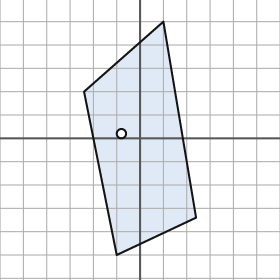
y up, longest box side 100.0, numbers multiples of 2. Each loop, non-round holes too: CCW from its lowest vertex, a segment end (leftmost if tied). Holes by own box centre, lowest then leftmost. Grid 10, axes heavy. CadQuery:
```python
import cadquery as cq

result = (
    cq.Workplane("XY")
    .moveTo(-10.0, -50.0)
    .lineTo(24.0, -34.0)
    .lineTo(10.0, 50.0)
    .lineTo(-24.0, 20.0)
    .close()
    .moveTo(-8.0, 2.0)
    .circle(2.0)
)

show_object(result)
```